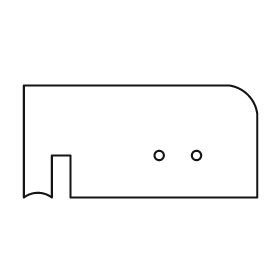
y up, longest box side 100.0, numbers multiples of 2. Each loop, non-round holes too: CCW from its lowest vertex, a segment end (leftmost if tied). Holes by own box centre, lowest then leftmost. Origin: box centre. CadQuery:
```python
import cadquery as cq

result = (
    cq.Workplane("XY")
    .moveTo(-50.0, -24.0)
    .threePointArc((-44.0, -22.0), (-38.0, -24.0))
    .lineTo(-38.0, -6.0)
    .lineTo(-30.0, -6.0)
    .lineTo(-30.0, -24.0)
    .lineTo(50.0, -24.0)
    .lineTo(50.0, 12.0)
    .threePointArc((46.0, 20.0), (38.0, 24.0))
    .lineTo(-50.0, 24.0)
    .close()
    .moveTo(8.0, -6.0)
    .circle(2.0)
    .moveTo(24.0, -6.0)
    .circle(2.0)
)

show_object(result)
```